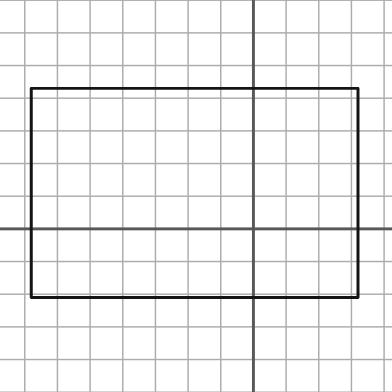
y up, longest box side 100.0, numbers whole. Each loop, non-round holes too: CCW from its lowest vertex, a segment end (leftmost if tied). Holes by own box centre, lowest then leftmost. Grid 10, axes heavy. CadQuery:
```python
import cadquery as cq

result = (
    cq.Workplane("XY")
    .moveTo(-68.0, -21.0)
    .lineTo(32.0, -21.0)
    .lineTo(32.0, 43.0)
    .lineTo(-68.0, 43.0)
    .close()
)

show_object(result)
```